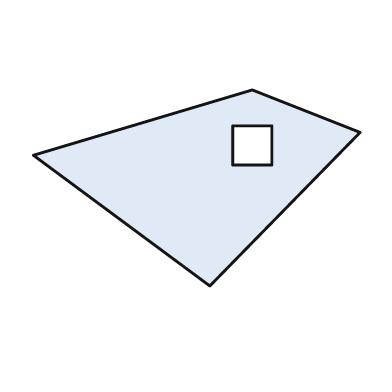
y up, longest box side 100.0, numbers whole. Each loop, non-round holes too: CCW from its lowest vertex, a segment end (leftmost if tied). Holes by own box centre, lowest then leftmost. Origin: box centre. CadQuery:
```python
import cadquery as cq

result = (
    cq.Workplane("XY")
    .moveTo(4.0, -30.0)
    .lineTo(50.0, 17.0)
    .lineTo(17.0, 30.0)
    .lineTo(-50.0, 10.0)
    .close()
    .moveTo(11.0, 7.0)
    .lineTo(23.0, 7.0)
    .lineTo(23.0, 19.0)
    .lineTo(11.0, 19.0)
    .close()
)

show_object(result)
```